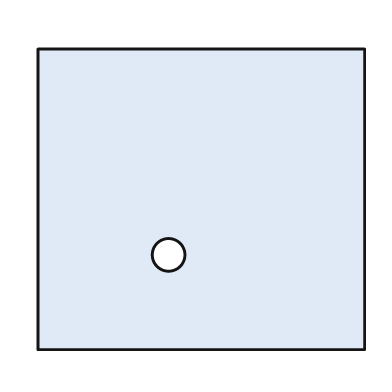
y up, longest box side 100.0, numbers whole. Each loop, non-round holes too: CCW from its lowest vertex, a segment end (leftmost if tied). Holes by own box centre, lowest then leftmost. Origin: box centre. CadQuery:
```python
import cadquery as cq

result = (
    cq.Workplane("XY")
    .moveTo(-50.0, -46.0)
    .lineTo(50.0, -46.0)
    .lineTo(50.0, 46.0)
    .lineTo(-50.0, 46.0)
    .close()
    .moveTo(-10.0, -17.0)
    .circle(5.0)
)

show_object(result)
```